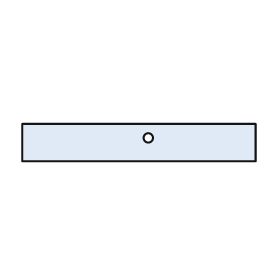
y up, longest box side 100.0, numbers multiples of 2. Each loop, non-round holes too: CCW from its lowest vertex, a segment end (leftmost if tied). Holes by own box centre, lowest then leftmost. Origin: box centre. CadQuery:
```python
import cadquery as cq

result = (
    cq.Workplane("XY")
    .moveTo(-50.0, -8.0)
    .lineTo(50.0, -8.0)
    .lineTo(50.0, 8.0)
    .lineTo(-50.0, 8.0)
    .close()
    .moveTo(4.0, 2.0)
    .circle(2.0)
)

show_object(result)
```